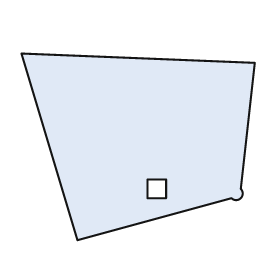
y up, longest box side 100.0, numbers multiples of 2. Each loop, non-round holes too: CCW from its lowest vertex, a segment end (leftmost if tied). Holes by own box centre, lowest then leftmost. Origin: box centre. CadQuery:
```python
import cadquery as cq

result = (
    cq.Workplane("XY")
    .moveTo(-26.0, -40.0)
    .lineTo(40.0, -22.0)
    .threePointArc((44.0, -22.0), (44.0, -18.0))
    .lineTo(50.0, 36.0)
    .lineTo(-50.0, 40.0)
    .close()
    .moveTo(4.0, -22.0)
    .lineTo(12.0, -22.0)
    .lineTo(12.0, -14.0)
    .lineTo(4.0, -14.0)
    .close()
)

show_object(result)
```